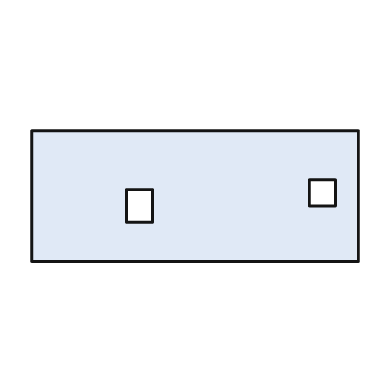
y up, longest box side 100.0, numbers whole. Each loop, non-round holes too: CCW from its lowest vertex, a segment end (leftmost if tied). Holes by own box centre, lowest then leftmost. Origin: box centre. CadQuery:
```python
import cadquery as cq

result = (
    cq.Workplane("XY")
    .moveTo(-50.0, -20.0)
    .lineTo(50.0, -20.0)
    .lineTo(50.0, 20.0)
    .lineTo(-50.0, 20.0)
    .close()
    .moveTo(-21.0, -8.0)
    .lineTo(-13.0, -8.0)
    .lineTo(-13.0, 2.0)
    .lineTo(-21.0, 2.0)
    .close()
    .moveTo(35.0, -3.0)
    .lineTo(43.0, -3.0)
    .lineTo(43.0, 5.0)
    .lineTo(35.0, 5.0)
    .close()
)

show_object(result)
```